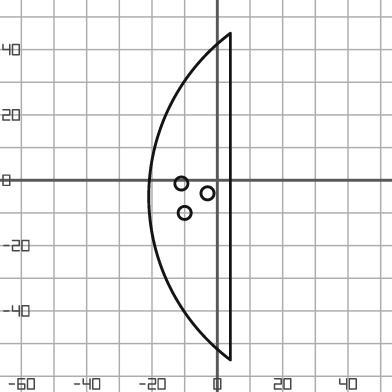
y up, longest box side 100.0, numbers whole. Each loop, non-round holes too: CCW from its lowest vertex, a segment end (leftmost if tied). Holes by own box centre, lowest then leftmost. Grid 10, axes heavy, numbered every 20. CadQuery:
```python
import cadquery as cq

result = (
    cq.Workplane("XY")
    .moveTo(4.0, -55.0)
    .lineTo(4.0, 45.0)
    .threePointArc((-21.0, -5.0), (4.0, -55.0))
    .close()
    .moveTo(-10.0, -10.0)
    .circle(2.0)
    .moveTo(-3.0, -4.0)
    .circle(2.0)
    .moveTo(-11.0, -1.0)
    .circle(2.0)
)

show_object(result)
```